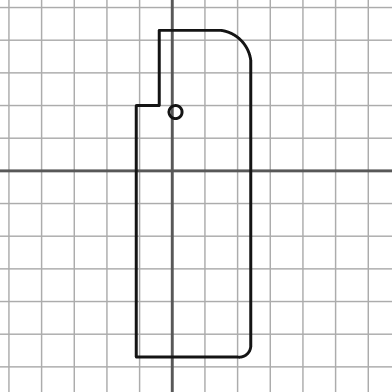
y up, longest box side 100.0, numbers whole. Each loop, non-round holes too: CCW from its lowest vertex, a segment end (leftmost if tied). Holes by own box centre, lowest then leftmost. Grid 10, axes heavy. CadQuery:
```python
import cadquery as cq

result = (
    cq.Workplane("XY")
    .moveTo(-11.0, -57.0)
    .lineTo(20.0, -57.0)
    .threePointArc((23.0, -56.0), (24.0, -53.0))
    .lineTo(24.0, 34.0)
    .threePointArc((21.0, 40.0), (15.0, 43.0))
    .lineTo(-4.0, 43.0)
    .lineTo(-4.0, 20.0)
    .lineTo(-11.0, 20.0)
    .close()
    .moveTo(1.0, 18.0)
    .circle(2.0)
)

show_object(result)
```